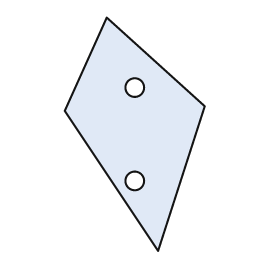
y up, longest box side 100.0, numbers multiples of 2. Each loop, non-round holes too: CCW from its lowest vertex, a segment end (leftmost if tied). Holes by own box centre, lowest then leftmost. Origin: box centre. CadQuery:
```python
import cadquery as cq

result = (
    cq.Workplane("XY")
    .moveTo(10.0, -50.0)
    .lineTo(30.0, 12.0)
    .lineTo(-12.0, 50.0)
    .lineTo(-30.0, 10.0)
    .close()
    .moveTo(0.0, -20.0)
    .circle(4.0)
    .moveTo(0.0, 20.0)
    .circle(4.0)
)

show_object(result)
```